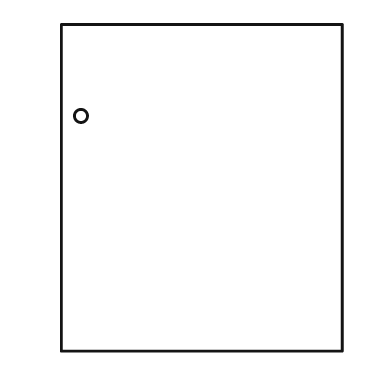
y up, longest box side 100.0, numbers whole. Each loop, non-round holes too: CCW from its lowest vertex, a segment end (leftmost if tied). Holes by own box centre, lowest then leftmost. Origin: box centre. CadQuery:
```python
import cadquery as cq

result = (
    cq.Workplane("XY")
    .moveTo(-43.0, -50.0)
    .lineTo(43.0, -50.0)
    .lineTo(43.0, 50.0)
    .lineTo(-43.0, 50.0)
    .close()
    .moveTo(-37.0, 22.0)
    .circle(2.0)
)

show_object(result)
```